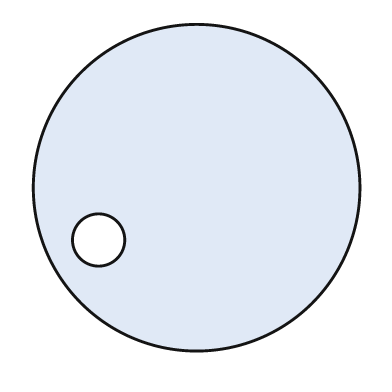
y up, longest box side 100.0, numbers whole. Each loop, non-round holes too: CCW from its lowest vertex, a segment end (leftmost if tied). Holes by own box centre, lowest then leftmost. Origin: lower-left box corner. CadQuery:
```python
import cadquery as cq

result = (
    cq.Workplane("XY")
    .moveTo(50.0, 50.0)
    .circle(50.0)
    .moveTo(20.0, 34.0)
    .circle(8.0)
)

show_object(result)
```